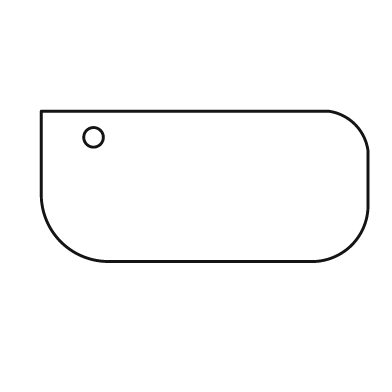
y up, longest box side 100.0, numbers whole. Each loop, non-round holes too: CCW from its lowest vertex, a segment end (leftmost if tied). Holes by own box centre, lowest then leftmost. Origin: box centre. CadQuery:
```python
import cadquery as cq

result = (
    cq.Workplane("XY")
    .moveTo(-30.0, -23.0)
    .lineTo(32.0, -23.0)
    .threePointArc((45.0, -18.0), (50.0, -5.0))
    .lineTo(50.0, 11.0)
    .threePointArc((46.0, 19.0), (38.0, 23.0))
    .lineTo(-50.0, 23.0)
    .lineTo(-50.0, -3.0)
    .threePointArc((-44.0, -17.0), (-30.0, -23.0))
    .close()
    .moveTo(-34.0, 15.0)
    .circle(3.0)
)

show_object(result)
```